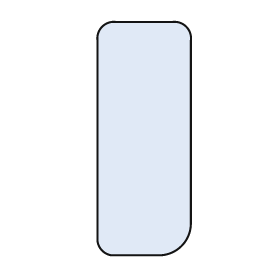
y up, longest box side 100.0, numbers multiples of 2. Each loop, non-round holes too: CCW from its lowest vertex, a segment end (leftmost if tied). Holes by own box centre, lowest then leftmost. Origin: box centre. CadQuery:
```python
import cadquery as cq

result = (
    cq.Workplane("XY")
    .moveTo(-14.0, -50.0)
    .lineTo(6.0, -50.0)
    .threePointArc((16.0, -46.0), (20.0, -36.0))
    .lineTo(20.0, 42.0)
    .threePointArc((18.0, 48.0), (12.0, 50.0))
    .lineTo(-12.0, 50.0)
    .threePointArc((-18.0, 48.0), (-20.0, 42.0))
    .lineTo(-20.0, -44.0)
    .threePointArc((-18.0, -48.0), (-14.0, -50.0))
    .close()
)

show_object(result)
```